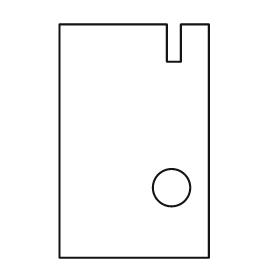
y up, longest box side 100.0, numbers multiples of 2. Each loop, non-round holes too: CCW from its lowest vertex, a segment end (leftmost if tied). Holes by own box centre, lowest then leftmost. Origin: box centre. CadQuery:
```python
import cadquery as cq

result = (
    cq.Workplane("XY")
    .moveTo(-32.0, -50.0)
    .lineTo(32.0, -50.0)
    .lineTo(32.0, 50.0)
    .lineTo(20.0, 50.0)
    .lineTo(20.0, 34.0)
    .lineTo(14.0, 34.0)
    .lineTo(14.0, 50.0)
    .lineTo(-32.0, 50.0)
    .close()
    .moveTo(16.0, -20.0)
    .circle(8.0)
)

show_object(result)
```